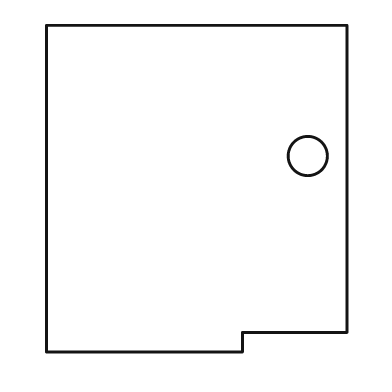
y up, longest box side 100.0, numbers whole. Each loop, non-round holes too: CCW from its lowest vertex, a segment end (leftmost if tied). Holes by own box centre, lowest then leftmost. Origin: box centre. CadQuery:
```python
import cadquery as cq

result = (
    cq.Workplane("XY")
    .moveTo(-46.0, -50.0)
    .lineTo(14.0, -50.0)
    .lineTo(14.0, -44.0)
    .lineTo(46.0, -44.0)
    .lineTo(46.0, 50.0)
    .lineTo(-46.0, 50.0)
    .close()
    .moveTo(34.0, 10.0)
    .circle(6.0)
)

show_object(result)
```